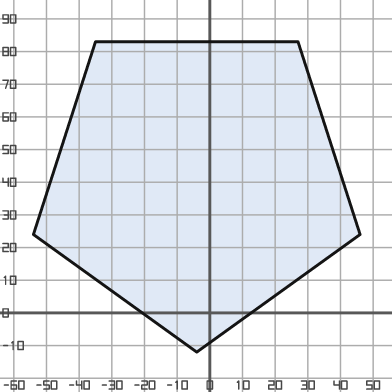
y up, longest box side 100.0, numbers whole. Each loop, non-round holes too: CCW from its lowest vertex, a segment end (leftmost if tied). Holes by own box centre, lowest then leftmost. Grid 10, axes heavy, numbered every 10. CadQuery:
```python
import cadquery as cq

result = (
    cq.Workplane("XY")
    .moveTo(-4.0, -12.0)
    .lineTo(46.0, 24.0)
    .lineTo(27.0, 83.0)
    .lineTo(-35.0, 83.0)
    .lineTo(-54.0, 24.0)
    .close()
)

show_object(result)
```